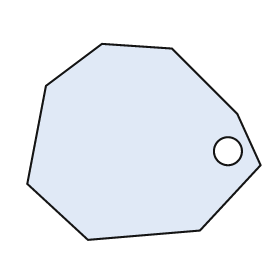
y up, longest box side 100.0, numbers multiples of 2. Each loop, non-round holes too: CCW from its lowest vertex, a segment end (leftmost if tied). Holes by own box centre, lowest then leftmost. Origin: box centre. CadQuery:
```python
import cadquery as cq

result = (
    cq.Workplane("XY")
    .moveTo(-24.0, -42.0)
    .lineTo(24.0, -38.0)
    .lineTo(50.0, -10.0)
    .lineTo(40.0, 12.0)
    .lineTo(12.0, 40.0)
    .lineTo(-18.0, 42.0)
    .lineTo(-42.0, 24.0)
    .lineTo(-50.0, -18.0)
    .close()
    .moveTo(36.0, -4.0)
    .circle(6.0)
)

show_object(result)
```